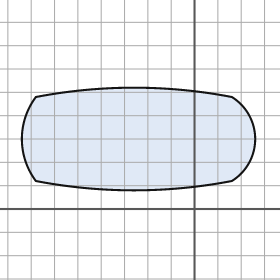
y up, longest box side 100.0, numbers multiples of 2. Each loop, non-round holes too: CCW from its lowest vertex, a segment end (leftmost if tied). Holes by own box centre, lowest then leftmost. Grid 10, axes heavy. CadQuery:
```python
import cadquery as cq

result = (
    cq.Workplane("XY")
    .moveTo(-68.0, 12.0)
    .threePointArc((-26.0, 8.0), (16.0, 12.0))
    .threePointArc((26.0, 30.0), (16.0, 48.0))
    .threePointArc((-26.0, 52.0), (-68.0, 48.0))
    .threePointArc((-74.0, 30.0), (-68.0, 12.0))
    .close()
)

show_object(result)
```